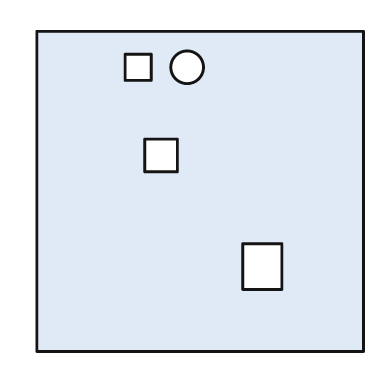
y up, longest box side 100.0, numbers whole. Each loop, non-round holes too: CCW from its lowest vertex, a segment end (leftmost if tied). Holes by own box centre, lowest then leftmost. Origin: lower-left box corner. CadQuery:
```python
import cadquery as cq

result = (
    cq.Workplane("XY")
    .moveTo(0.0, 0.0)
    .lineTo(100.0, 0.0)
    .lineTo(100.0, 98.0)
    .lineTo(0.0, 98.0)
    .close()
    .moveTo(63.0, 19.0)
    .lineTo(75.0, 19.0)
    .lineTo(75.0, 33.0)
    .lineTo(63.0, 33.0)
    .close()
    .moveTo(33.0, 55.0)
    .lineTo(43.0, 55.0)
    .lineTo(43.0, 65.0)
    .lineTo(33.0, 65.0)
    .close()
    .moveTo(27.0, 83.0)
    .lineTo(35.0, 83.0)
    .lineTo(35.0, 91.0)
    .lineTo(27.0, 91.0)
    .close()
    .moveTo(46.0, 87.0)
    .circle(5.0)
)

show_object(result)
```